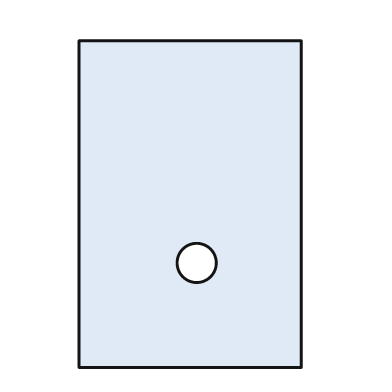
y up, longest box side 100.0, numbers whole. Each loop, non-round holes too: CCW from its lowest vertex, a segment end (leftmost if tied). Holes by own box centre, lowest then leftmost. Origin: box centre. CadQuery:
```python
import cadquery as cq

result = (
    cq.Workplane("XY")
    .moveTo(-34.0, -50.0)
    .lineTo(34.0, -50.0)
    .lineTo(34.0, 50.0)
    .lineTo(-34.0, 50.0)
    .close()
    .moveTo(2.0, -18.0)
    .circle(6.0)
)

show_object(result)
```